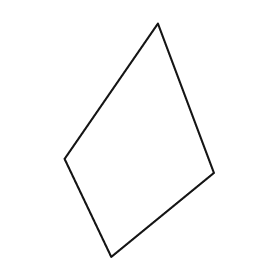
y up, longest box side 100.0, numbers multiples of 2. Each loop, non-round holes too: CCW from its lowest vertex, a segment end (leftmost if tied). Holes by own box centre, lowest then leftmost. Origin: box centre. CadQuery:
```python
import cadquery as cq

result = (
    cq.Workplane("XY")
    .moveTo(-12.0, -50.0)
    .lineTo(32.0, -14.0)
    .lineTo(8.0, 50.0)
    .lineTo(-32.0, -8.0)
    .close()
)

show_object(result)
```